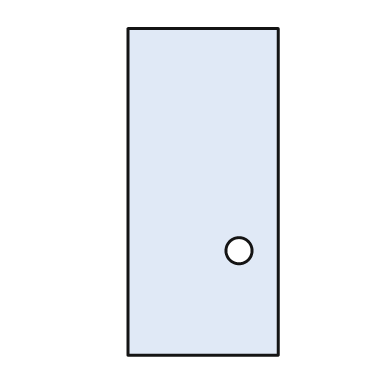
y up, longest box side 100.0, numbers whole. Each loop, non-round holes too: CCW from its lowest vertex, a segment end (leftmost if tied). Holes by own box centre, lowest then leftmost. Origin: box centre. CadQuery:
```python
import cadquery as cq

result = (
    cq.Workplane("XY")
    .moveTo(-23.0, -50.0)
    .lineTo(23.0, -50.0)
    .lineTo(23.0, 50.0)
    .lineTo(-23.0, 50.0)
    .close()
    .moveTo(11.0, -18.0)
    .circle(4.0)
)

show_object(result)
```